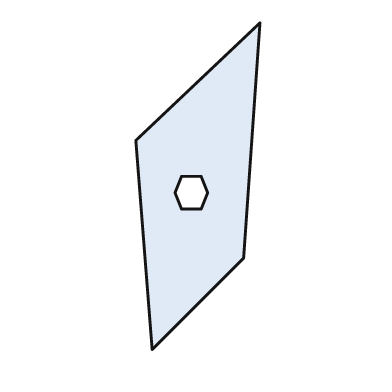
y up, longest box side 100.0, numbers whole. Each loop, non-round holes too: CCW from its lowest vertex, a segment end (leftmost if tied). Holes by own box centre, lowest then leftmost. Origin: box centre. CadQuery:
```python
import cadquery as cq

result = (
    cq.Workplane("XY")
    .moveTo(-14.0, -50.0)
    .lineTo(14.0, -22.0)
    .lineTo(19.0, 50.0)
    .lineTo(-19.0, 14.0)
    .close()
    .moveTo(-5.0, -7.0)
    .lineTo(1.0, -7.0)
    .lineTo(3.0, -2.0)
    .lineTo(1.0, 3.0)
    .lineTo(-5.0, 3.0)
    .lineTo(-7.0, -2.0)
    .close()
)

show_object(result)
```